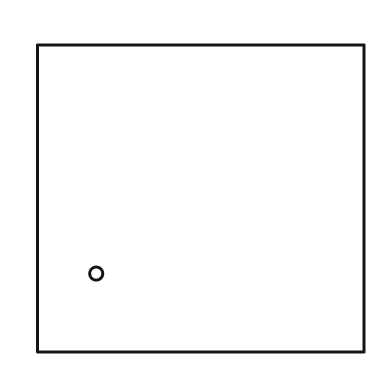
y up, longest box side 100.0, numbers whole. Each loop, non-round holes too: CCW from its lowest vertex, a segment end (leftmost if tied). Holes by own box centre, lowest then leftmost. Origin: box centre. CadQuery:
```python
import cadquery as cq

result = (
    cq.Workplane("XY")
    .moveTo(-50.0, -47.0)
    .lineTo(50.0, -47.0)
    .lineTo(50.0, 47.0)
    .lineTo(-50.0, 47.0)
    .close()
    .moveTo(-32.0, -23.0)
    .circle(2.0)
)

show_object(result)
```